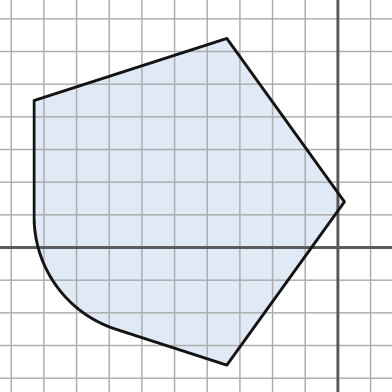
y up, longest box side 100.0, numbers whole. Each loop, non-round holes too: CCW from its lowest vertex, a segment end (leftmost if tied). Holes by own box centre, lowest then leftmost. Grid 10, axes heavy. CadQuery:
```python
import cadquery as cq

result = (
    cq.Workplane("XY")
    .moveTo(-34.0, -36.0)
    .lineTo(2.0, 14.0)
    .lineTo(-34.0, 64.0)
    .lineTo(-93.0, 45.0)
    .lineTo(-93.0, 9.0)
    .threePointArc((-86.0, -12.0), (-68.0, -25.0))
    .close()
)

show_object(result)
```